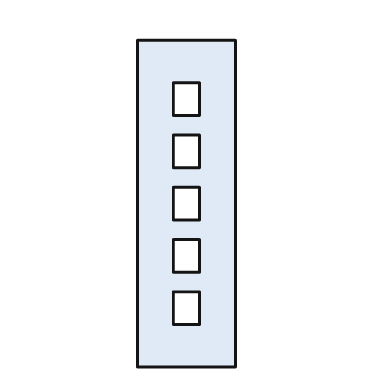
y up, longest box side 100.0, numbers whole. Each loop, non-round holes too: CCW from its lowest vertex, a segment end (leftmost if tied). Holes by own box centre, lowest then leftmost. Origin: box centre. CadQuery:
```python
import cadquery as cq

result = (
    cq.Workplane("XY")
    .moveTo(-15.0, -50.0)
    .lineTo(15.0, -50.0)
    .lineTo(15.0, 50.0)
    .lineTo(-15.0, 50.0)
    .close()
    .moveTo(-4.0, -37.0)
    .lineTo(4.0, -37.0)
    .lineTo(4.0, -27.0)
    .lineTo(-4.0, -27.0)
    .close()
    .moveTo(-4.0, -21.0)
    .lineTo(4.0, -21.0)
    .lineTo(4.0, -11.0)
    .lineTo(-4.0, -11.0)
    .close()
    .moveTo(-4.0, -5.0)
    .lineTo(4.0, -5.0)
    .lineTo(4.0, 5.0)
    .lineTo(-4.0, 5.0)
    .close()
    .moveTo(-4.0, 11.0)
    .lineTo(4.0, 11.0)
    .lineTo(4.0, 21.0)
    .lineTo(-4.0, 21.0)
    .close()
    .moveTo(-4.0, 27.0)
    .lineTo(4.0, 27.0)
    .lineTo(4.0, 37.0)
    .lineTo(-4.0, 37.0)
    .close()
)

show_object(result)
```